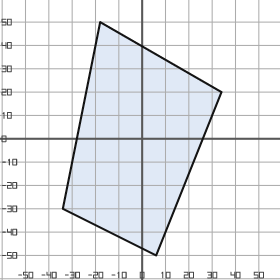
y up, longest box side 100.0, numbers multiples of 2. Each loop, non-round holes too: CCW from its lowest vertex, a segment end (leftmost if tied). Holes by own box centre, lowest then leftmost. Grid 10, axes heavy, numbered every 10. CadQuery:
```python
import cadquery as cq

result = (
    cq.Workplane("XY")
    .moveTo(6.0, -50.0)
    .lineTo(34.0, 20.0)
    .lineTo(-18.0, 50.0)
    .lineTo(-34.0, -30.0)
    .close()
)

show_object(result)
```